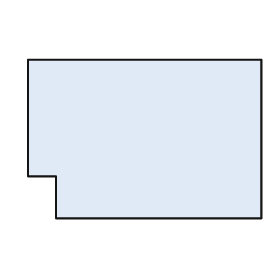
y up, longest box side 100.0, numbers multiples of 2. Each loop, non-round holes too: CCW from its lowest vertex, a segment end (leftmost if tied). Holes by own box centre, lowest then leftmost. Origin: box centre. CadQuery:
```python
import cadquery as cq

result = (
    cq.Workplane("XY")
    .moveTo(-38.0, -34.0)
    .lineTo(50.0, -34.0)
    .lineTo(50.0, 34.0)
    .lineTo(-50.0, 34.0)
    .lineTo(-50.0, -16.0)
    .lineTo(-38.0, -16.0)
    .close()
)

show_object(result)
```